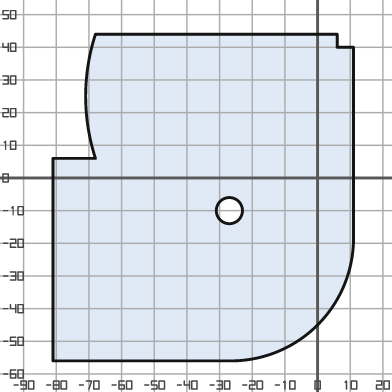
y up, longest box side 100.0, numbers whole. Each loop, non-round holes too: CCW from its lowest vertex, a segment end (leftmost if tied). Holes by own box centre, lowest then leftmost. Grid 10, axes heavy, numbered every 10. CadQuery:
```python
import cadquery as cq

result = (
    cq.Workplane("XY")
    .moveTo(-81.0, -56.0)
    .lineTo(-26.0, -56.0)
    .threePointArc((0.0, -45.0), (11.0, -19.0))
    .lineTo(11.0, 40.0)
    .lineTo(6.0, 40.0)
    .lineTo(6.0, 44.0)
    .lineTo(-68.0, 44.0)
    .threePointArc((-71.0, 25.0), (-68.0, 6.0))
    .lineTo(-81.0, 6.0)
    .close()
    .moveTo(-27.0, -10.0)
    .circle(4.0)
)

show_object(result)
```